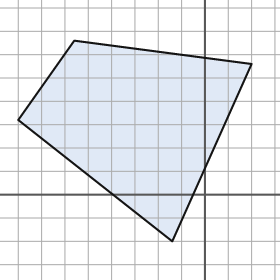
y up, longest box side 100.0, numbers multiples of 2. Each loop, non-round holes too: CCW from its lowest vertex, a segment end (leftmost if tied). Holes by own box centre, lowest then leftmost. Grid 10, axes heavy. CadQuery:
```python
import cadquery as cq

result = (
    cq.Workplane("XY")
    .moveTo(-14.0, -20.0)
    .lineTo(20.0, 56.0)
    .lineTo(-56.0, 66.0)
    .lineTo(-80.0, 32.0)
    .close()
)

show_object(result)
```